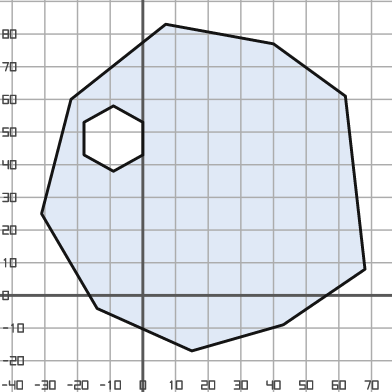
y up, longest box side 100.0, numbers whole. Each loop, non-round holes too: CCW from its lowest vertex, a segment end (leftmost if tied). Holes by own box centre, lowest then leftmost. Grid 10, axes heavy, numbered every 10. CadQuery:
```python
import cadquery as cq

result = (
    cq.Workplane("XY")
    .moveTo(15.0, -17.0)
    .lineTo(43.0, -9.0)
    .lineTo(68.0, 8.0)
    .lineTo(62.0, 61.0)
    .lineTo(40.0, 77.0)
    .lineTo(7.0, 83.0)
    .lineTo(-22.0, 60.0)
    .lineTo(-31.0, 25.0)
    .lineTo(-14.0, -4.0)
    .close()
    .moveTo(-9.0, 38.0)
    .lineTo(0.0, 43.0)
    .lineTo(0.0, 53.0)
    .lineTo(-9.0, 58.0)
    .lineTo(-18.0, 53.0)
    .lineTo(-18.0, 43.0)
    .close()
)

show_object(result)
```